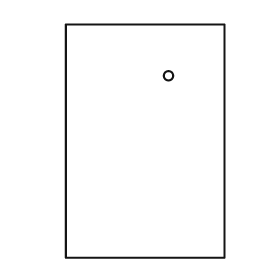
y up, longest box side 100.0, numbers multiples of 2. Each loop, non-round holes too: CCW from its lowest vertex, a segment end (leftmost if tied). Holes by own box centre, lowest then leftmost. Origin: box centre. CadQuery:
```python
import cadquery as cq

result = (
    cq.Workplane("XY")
    .moveTo(-34.0, -50.0)
    .lineTo(34.0, -50.0)
    .lineTo(34.0, 50.0)
    .lineTo(-34.0, 50.0)
    .close()
    .moveTo(10.0, 28.0)
    .circle(2.0)
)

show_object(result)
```